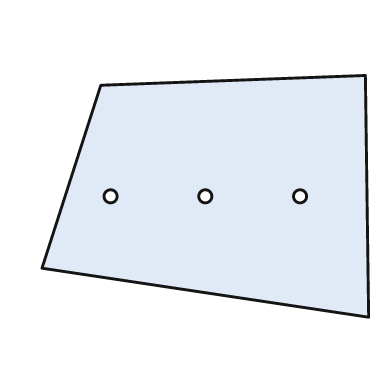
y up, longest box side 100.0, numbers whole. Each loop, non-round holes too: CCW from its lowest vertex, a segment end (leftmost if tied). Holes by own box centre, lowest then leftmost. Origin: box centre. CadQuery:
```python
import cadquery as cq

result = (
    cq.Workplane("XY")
    .moveTo(50.0, -37.0)
    .lineTo(49.0, 37.0)
    .lineTo(-32.0, 34.0)
    .lineTo(-50.0, -22.0)
    .close()
    .moveTo(-29.0, 0.0)
    .circle(2.0)
    .moveTo(0.0, 0.0)
    .circle(2.0)
    .moveTo(29.0, 0.0)
    .circle(2.0)
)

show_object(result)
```